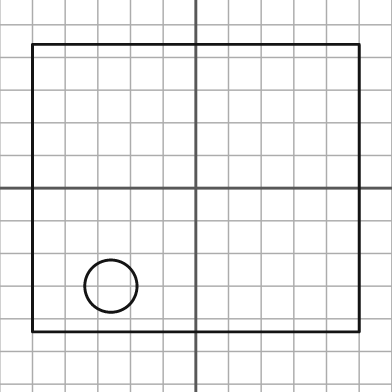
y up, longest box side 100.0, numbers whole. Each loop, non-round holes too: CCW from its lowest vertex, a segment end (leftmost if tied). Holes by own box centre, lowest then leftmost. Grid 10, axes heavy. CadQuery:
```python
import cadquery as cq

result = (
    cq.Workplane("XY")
    .moveTo(-50.0, -44.0)
    .lineTo(50.0, -44.0)
    .lineTo(50.0, 44.0)
    .lineTo(-50.0, 44.0)
    .close()
    .moveTo(-26.0, -30.0)
    .circle(8.0)
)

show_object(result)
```